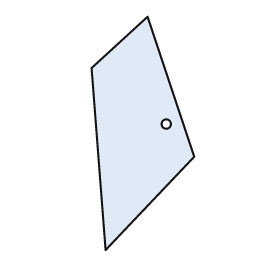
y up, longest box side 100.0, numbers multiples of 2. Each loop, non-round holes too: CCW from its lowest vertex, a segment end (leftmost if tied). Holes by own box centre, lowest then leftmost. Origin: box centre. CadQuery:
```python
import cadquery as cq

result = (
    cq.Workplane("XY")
    .moveTo(-16.0, -50.0)
    .lineTo(22.0, -10.0)
    .lineTo(2.0, 50.0)
    .lineTo(-22.0, 28.0)
    .close()
    .moveTo(10.0, 4.0)
    .circle(2.0)
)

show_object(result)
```